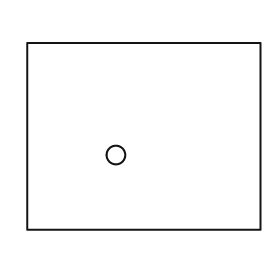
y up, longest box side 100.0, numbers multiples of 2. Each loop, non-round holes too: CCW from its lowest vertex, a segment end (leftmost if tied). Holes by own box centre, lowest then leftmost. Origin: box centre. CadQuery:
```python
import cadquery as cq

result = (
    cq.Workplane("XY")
    .moveTo(-50.0, -40.0)
    .lineTo(50.0, -40.0)
    .lineTo(50.0, 40.0)
    .lineTo(-50.0, 40.0)
    .close()
    .moveTo(-12.0, -8.0)
    .circle(4.0)
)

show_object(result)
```